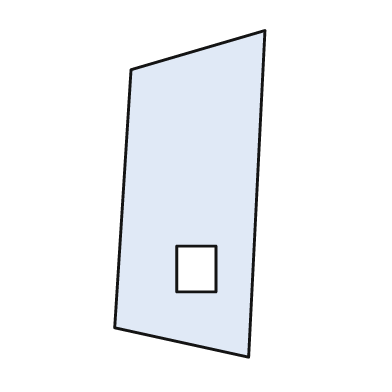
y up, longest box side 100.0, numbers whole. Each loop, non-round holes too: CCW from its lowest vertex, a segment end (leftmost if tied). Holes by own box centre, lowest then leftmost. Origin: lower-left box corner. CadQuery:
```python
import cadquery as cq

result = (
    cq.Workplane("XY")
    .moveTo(41.0, 0.0)
    .lineTo(46.0, 100.0)
    .lineTo(5.0, 88.0)
    .lineTo(0.0, 9.0)
    .close()
    .moveTo(19.0, 20.0)
    .lineTo(31.0, 20.0)
    .lineTo(31.0, 34.0)
    .lineTo(19.0, 34.0)
    .close()
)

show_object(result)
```